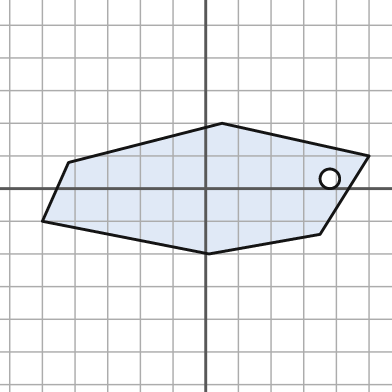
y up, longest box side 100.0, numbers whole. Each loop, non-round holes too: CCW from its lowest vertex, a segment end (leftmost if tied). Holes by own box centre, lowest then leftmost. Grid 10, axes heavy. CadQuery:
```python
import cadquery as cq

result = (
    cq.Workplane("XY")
    .moveTo(1.0, -20.0)
    .lineTo(35.0, -14.0)
    .lineTo(50.0, 10.0)
    .lineTo(5.0, 20.0)
    .lineTo(-42.0, 8.0)
    .lineTo(-50.0, -10.0)
    .close()
    .moveTo(38.0, 3.0)
    .circle(3.0)
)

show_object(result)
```